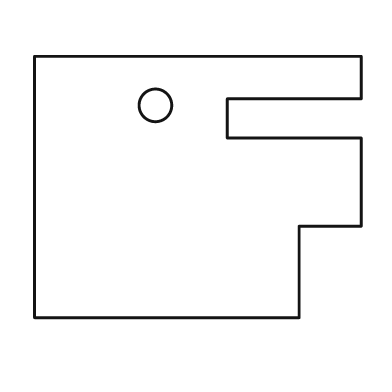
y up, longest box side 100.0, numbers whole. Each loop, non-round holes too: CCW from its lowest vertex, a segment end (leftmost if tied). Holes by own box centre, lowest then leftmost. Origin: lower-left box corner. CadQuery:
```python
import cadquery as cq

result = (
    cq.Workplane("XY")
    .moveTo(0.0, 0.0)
    .lineTo(81.0, 0.0)
    .lineTo(81.0, 28.0)
    .lineTo(100.0, 28.0)
    .lineTo(100.0, 55.0)
    .lineTo(59.0, 55.0)
    .lineTo(59.0, 67.0)
    .lineTo(100.0, 67.0)
    .lineTo(100.0, 80.0)
    .lineTo(0.0, 80.0)
    .close()
    .moveTo(37.0, 65.0)
    .circle(5.0)
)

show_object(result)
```